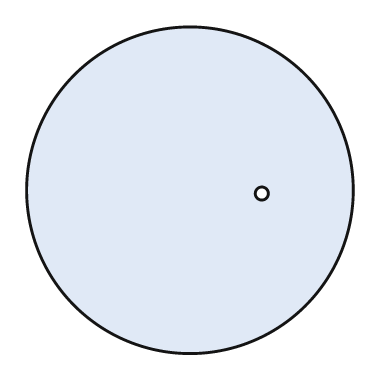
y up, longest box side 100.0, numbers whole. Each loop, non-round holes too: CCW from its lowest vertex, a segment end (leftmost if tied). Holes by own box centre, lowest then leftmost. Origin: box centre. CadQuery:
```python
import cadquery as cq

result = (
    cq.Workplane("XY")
    .moveTo(0.0, 0.0)
    .circle(50.0)
    .moveTo(22.0, -1.0)
    .circle(2.0)
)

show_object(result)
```